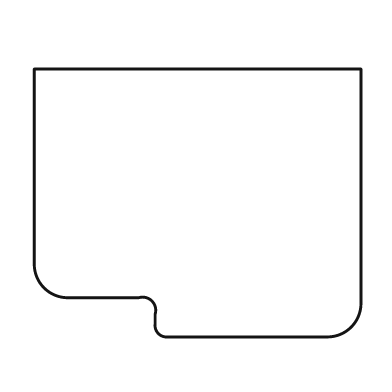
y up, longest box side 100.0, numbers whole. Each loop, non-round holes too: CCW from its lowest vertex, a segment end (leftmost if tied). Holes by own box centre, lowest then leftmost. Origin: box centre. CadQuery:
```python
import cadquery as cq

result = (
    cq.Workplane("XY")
    .moveTo(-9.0, -41.0)
    .lineTo(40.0, -41.0)
    .threePointArc((47.0, -38.0), (50.0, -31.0))
    .lineTo(50.0, 41.0)
    .lineTo(-50.0, 41.0)
    .lineTo(-50.0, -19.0)
    .threePointArc((-47.0, -26.0), (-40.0, -29.0))
    .lineTo(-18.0, -29.0)
    .threePointArc((-14.0, -30.0), (-13.0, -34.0))
    .lineTo(-13.0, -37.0)
    .threePointArc((-12.0, -40.0), (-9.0, -41.0))
    .close()
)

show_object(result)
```